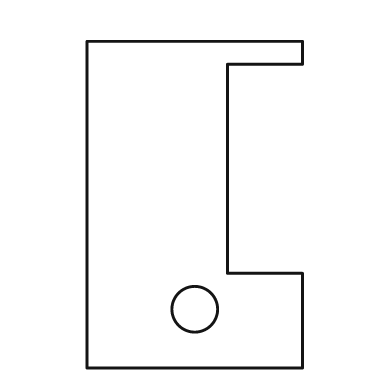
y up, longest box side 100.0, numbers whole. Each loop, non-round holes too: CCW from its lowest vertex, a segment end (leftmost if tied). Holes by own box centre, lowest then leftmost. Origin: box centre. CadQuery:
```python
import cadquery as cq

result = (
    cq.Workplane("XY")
    .moveTo(-33.0, -50.0)
    .lineTo(33.0, -50.0)
    .lineTo(33.0, -21.0)
    .lineTo(10.0, -21.0)
    .lineTo(10.0, 43.0)
    .lineTo(33.0, 43.0)
    .lineTo(33.0, 50.0)
    .lineTo(-33.0, 50.0)
    .close()
    .moveTo(0.0, -32.0)
    .circle(7.0)
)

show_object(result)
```